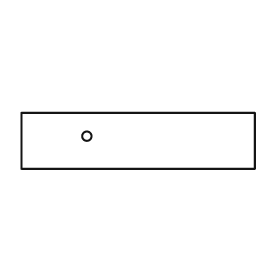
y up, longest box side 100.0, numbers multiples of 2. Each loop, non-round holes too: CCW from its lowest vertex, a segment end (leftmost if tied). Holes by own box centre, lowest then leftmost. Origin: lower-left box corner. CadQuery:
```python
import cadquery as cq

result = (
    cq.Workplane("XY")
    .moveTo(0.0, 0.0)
    .lineTo(100.0, 0.0)
    .lineTo(100.0, 24.0)
    .lineTo(0.0, 24.0)
    .close()
    .moveTo(28.0, 14.0)
    .circle(2.0)
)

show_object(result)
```